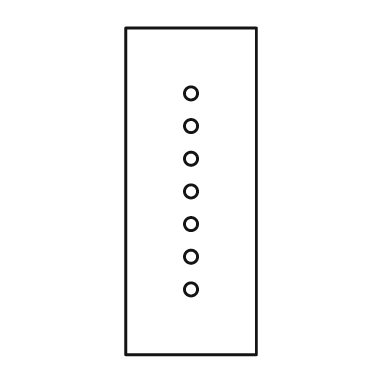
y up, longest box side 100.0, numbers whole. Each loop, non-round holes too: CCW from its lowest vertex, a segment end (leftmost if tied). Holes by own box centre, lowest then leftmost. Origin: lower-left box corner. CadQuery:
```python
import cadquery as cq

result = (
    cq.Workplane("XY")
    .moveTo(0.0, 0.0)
    .lineTo(40.0, 0.0)
    .lineTo(40.0, 100.0)
    .lineTo(0.0, 100.0)
    .close()
    .moveTo(20.0, 20.0)
    .circle(2.0)
    .moveTo(20.0, 30.0)
    .circle(2.0)
    .moveTo(20.0, 40.0)
    .circle(2.0)
    .moveTo(20.0, 50.0)
    .circle(2.0)
    .moveTo(20.0, 60.0)
    .circle(2.0)
    .moveTo(20.0, 70.0)
    .circle(2.0)
    .moveTo(20.0, 80.0)
    .circle(2.0)
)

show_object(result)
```